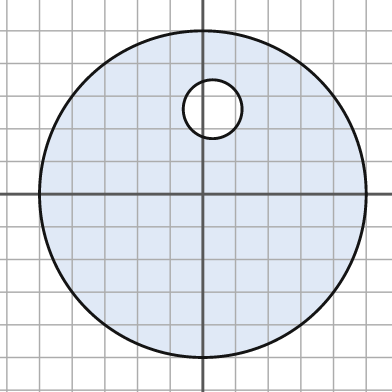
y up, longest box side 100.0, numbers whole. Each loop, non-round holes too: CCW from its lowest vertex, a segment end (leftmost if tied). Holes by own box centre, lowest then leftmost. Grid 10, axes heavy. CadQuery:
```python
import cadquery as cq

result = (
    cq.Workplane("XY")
    .moveTo(0.0, 0.0)
    .circle(50.0)
    .moveTo(3.0, 26.0)
    .circle(9.0)
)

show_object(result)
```